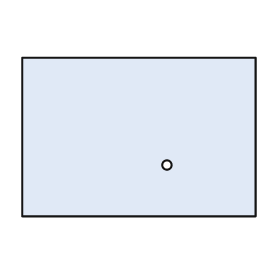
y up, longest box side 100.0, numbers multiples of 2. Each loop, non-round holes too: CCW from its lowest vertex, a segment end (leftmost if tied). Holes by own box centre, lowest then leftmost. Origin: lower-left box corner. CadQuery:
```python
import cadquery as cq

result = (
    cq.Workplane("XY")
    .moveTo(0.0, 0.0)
    .lineTo(100.0, 0.0)
    .lineTo(100.0, 68.0)
    .lineTo(0.0, 68.0)
    .close()
    .moveTo(62.0, 22.0)
    .circle(2.0)
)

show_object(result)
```